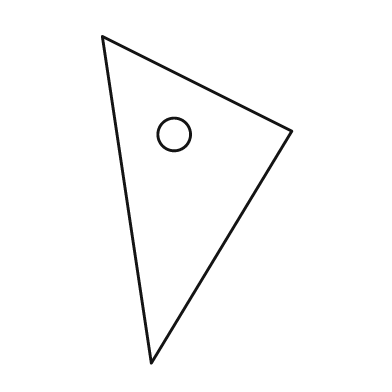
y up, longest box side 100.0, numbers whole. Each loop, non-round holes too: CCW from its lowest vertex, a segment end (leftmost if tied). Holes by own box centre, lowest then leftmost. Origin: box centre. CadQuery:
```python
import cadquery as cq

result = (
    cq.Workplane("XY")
    .moveTo(-14.0, -50.0)
    .lineTo(29.0, 21.0)
    .lineTo(-29.0, 50.0)
    .close()
    .moveTo(-7.0, 20.0)
    .circle(5.0)
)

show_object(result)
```